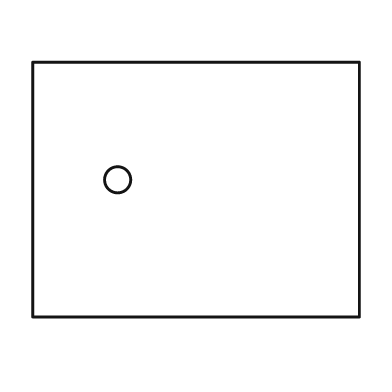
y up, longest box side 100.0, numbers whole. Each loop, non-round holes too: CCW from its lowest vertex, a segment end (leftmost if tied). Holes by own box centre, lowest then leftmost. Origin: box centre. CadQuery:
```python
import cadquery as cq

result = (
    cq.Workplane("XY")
    .moveTo(-50.0, -39.0)
    .lineTo(50.0, -39.0)
    .lineTo(50.0, 39.0)
    .lineTo(-50.0, 39.0)
    .close()
    .moveTo(-24.0, 3.0)
    .circle(4.0)
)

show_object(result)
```